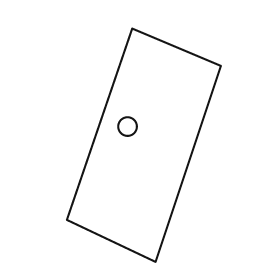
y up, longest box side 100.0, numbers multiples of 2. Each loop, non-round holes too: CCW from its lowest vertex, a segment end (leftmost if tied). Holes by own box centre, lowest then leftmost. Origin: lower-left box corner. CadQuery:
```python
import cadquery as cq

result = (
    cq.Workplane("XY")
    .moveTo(38.0, 0.0)
    .lineTo(66.0, 84.0)
    .lineTo(28.0, 100.0)
    .lineTo(0.0, 18.0)
    .close()
    .moveTo(26.0, 58.0)
    .circle(4.0)
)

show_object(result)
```